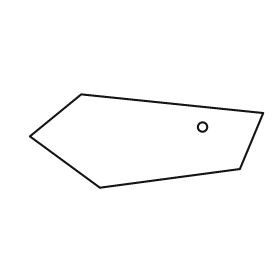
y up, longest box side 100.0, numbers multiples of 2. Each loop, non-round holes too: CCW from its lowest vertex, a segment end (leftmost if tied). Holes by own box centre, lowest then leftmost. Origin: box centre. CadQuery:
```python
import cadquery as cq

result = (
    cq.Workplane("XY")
    .moveTo(-20.0, -20.0)
    .lineTo(40.0, -12.0)
    .lineTo(50.0, 12.0)
    .lineTo(-28.0, 20.0)
    .lineTo(-50.0, 2.0)
    .close()
    .moveTo(24.0, 6.0)
    .circle(2.0)
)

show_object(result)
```